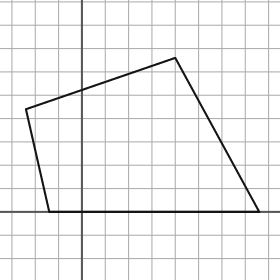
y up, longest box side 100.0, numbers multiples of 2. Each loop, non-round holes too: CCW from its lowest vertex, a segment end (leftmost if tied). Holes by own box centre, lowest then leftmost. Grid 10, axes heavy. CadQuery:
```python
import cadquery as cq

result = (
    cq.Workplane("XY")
    .moveTo(-14.0, 0.0)
    .lineTo(76.0, 0.0)
    .lineTo(40.0, 66.0)
    .lineTo(-24.0, 44.0)
    .close()
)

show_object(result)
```